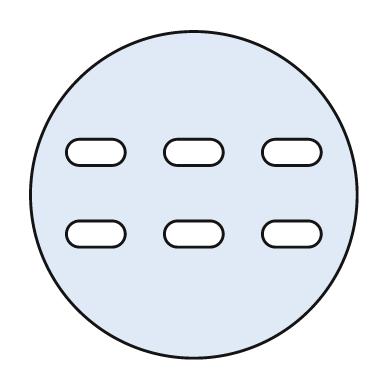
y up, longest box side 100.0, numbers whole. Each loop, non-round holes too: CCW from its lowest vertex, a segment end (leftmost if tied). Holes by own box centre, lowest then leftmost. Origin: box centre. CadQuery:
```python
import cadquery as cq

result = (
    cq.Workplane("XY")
    .moveTo(0.0, 0.0)
    .circle(50.0)
    .moveTo(-35.0, -16.0)
    .lineTo(-25.0, -16.0)
    .threePointArc((-21.0, -12.0), (-25.0, -8.0))
    .lineTo(-35.0, -8.0)
    .threePointArc((-39.0, -12.0), (-35.0, -16.0))
    .close()
    .moveTo(-5.0, -16.0)
    .lineTo(5.0, -16.0)
    .threePointArc((9.0, -12.0), (5.0, -8.0))
    .lineTo(-5.0, -8.0)
    .threePointArc((-9.0, -12.0), (-5.0, -16.0))
    .close()
    .moveTo(25.0, -16.0)
    .lineTo(35.0, -16.0)
    .threePointArc((39.0, -12.0), (35.0, -8.0))
    .lineTo(25.0, -8.0)
    .threePointArc((21.0, -12.0), (25.0, -16.0))
    .close()
    .moveTo(-35.0, 9.0)
    .lineTo(-25.0, 9.0)
    .threePointArc((-21.0, 13.0), (-25.0, 17.0))
    .lineTo(-35.0, 17.0)
    .threePointArc((-39.0, 13.0), (-35.0, 9.0))
    .close()
    .moveTo(-5.0, 9.0)
    .lineTo(5.0, 9.0)
    .threePointArc((9.0, 13.0), (5.0, 17.0))
    .lineTo(-5.0, 17.0)
    .threePointArc((-9.0, 13.0), (-5.0, 9.0))
    .close()
    .moveTo(25.0, 9.0)
    .lineTo(35.0, 9.0)
    .threePointArc((39.0, 13.0), (35.0, 17.0))
    .lineTo(25.0, 17.0)
    .threePointArc((21.0, 13.0), (25.0, 9.0))
    .close()
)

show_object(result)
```